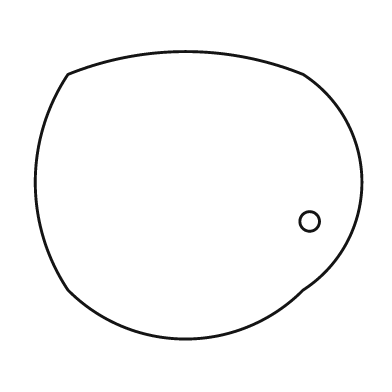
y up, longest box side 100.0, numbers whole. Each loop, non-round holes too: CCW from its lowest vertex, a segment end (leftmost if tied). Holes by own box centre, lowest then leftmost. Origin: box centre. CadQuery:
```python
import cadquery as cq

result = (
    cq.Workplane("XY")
    .moveTo(-40.0, -29.0)
    .threePointArc((-4.0, -44.0), (32.0, -29.0))
    .threePointArc((50.0, 4.0), (32.0, 37.0))
    .threePointArc((-4.0, 44.0), (-40.0, 37.0))
    .threePointArc((-50.0, 4.0), (-40.0, -29.0))
    .close()
    .moveTo(34.0, -8.0)
    .circle(3.0)
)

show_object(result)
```